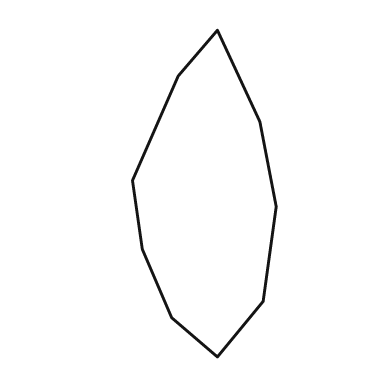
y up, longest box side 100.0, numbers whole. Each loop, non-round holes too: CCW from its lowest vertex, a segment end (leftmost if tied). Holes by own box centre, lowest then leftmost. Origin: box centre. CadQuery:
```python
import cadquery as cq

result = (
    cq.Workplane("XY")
    .moveTo(4.0, -50.0)
    .lineTo(18.0, -33.0)
    .lineTo(22.0, -4.0)
    .lineTo(17.0, 22.0)
    .lineTo(4.0, 50.0)
    .lineTo(-8.0, 36.0)
    .lineTo(-22.0, 4.0)
    .lineTo(-19.0, -17.0)
    .lineTo(-10.0, -38.0)
    .close()
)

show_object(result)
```